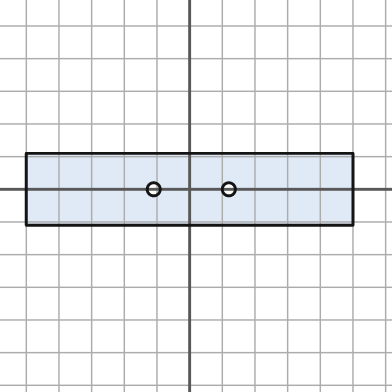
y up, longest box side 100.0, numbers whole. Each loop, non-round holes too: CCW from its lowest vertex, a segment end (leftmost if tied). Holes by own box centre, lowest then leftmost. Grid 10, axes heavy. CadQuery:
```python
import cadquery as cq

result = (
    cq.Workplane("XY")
    .moveTo(-50.0, -11.0)
    .lineTo(50.0, -11.0)
    .lineTo(50.0, 11.0)
    .lineTo(-50.0, 11.0)
    .close()
    .moveTo(-11.0, 0.0)
    .circle(2.0)
    .moveTo(12.0, 0.0)
    .circle(2.0)
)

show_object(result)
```